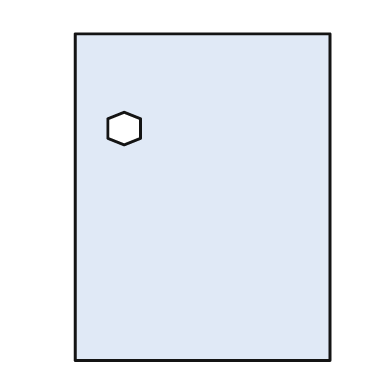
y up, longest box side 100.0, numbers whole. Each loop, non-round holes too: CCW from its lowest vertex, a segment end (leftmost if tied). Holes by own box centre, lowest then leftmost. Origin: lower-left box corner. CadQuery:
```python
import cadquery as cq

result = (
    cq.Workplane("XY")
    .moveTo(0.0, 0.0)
    .lineTo(78.0, 0.0)
    .lineTo(78.0, 100.0)
    .lineTo(0.0, 100.0)
    .close()
    .moveTo(15.0, 66.0)
    .lineTo(20.0, 68.0)
    .lineTo(20.0, 74.0)
    .lineTo(15.0, 76.0)
    .lineTo(10.0, 74.0)
    .lineTo(10.0, 68.0)
    .close()
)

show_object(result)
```